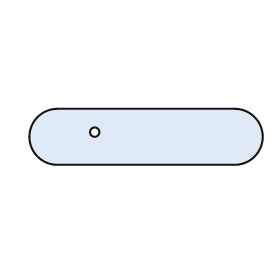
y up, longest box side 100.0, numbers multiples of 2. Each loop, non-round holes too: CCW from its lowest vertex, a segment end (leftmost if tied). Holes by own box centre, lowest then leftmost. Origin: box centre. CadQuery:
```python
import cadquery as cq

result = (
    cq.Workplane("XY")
    .moveTo(-38.0, -12.0)
    .lineTo(38.0, -12.0)
    .threePointArc((50.0, 0.0), (38.0, 12.0))
    .lineTo(-38.0, 12.0)
    .threePointArc((-50.0, 0.0), (-38.0, -12.0))
    .close()
    .moveTo(-22.0, 2.0)
    .circle(2.0)
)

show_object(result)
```